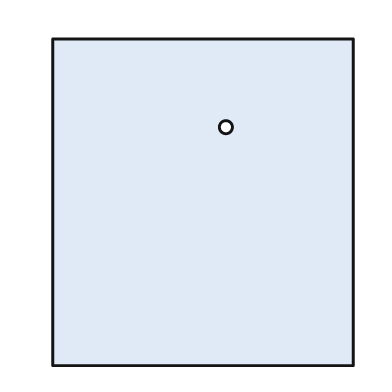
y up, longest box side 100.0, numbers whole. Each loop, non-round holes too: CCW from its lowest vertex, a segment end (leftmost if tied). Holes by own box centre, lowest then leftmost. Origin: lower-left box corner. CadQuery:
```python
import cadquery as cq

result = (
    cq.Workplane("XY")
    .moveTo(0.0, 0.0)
    .lineTo(92.0, 0.0)
    .lineTo(92.0, 100.0)
    .lineTo(0.0, 100.0)
    .close()
    .moveTo(53.0, 73.0)
    .circle(2.0)
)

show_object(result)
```